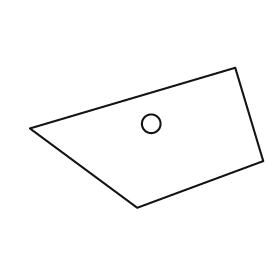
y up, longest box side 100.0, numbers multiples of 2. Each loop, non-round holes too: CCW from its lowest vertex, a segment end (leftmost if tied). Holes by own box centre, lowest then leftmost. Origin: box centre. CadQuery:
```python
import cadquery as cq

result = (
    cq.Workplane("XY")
    .moveTo(-4.0, -30.0)
    .lineTo(50.0, -10.0)
    .lineTo(38.0, 30.0)
    .lineTo(-50.0, 4.0)
    .close()
    .moveTo(2.0, 6.0)
    .circle(4.0)
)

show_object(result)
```